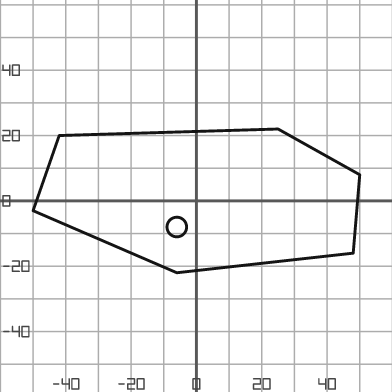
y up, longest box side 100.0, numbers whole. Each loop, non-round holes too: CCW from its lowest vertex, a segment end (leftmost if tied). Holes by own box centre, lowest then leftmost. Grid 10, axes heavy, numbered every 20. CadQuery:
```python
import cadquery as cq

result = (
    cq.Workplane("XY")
    .moveTo(-6.0, -22.0)
    .lineTo(48.0, -16.0)
    .lineTo(50.0, 8.0)
    .lineTo(25.0, 22.0)
    .lineTo(-42.0, 20.0)
    .lineTo(-50.0, -3.0)
    .close()
    .moveTo(-6.0, -8.0)
    .circle(3.0)
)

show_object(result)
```